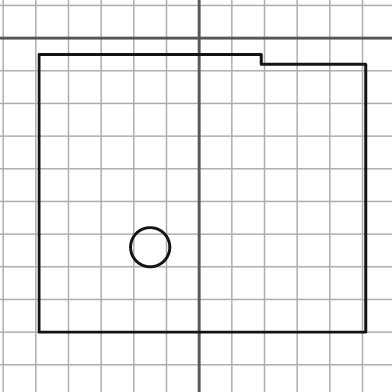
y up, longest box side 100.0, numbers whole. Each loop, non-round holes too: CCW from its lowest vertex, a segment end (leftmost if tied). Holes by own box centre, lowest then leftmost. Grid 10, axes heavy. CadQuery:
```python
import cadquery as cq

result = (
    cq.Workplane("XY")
    .moveTo(-49.0, -90.0)
    .lineTo(51.0, -90.0)
    .lineTo(51.0, -8.0)
    .lineTo(19.0, -8.0)
    .lineTo(19.0, -5.0)
    .lineTo(-49.0, -5.0)
    .close()
    .moveTo(-15.0, -64.0)
    .circle(6.0)
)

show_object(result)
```